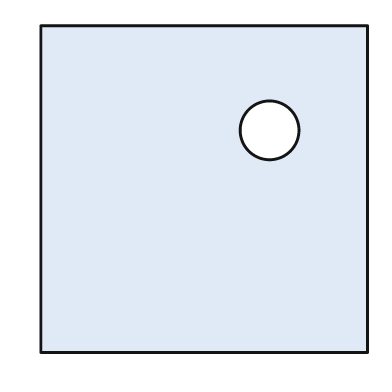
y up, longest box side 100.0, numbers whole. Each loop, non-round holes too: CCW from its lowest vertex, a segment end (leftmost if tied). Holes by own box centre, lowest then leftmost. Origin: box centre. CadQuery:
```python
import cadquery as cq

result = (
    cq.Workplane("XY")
    .moveTo(-50.0, -50.0)
    .lineTo(50.0, -50.0)
    .lineTo(50.0, 50.0)
    .lineTo(-50.0, 50.0)
    .close()
    .moveTo(20.0, 18.0)
    .circle(9.0)
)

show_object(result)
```